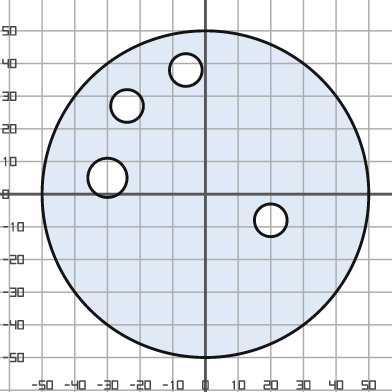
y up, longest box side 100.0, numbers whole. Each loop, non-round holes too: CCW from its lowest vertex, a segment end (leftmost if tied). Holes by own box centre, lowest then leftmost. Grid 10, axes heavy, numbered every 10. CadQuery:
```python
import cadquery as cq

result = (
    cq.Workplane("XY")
    .moveTo(0.0, 0.0)
    .circle(50.0)
    .moveTo(20.0, -8.0)
    .circle(5.0)
    .moveTo(-30.0, 5.0)
    .circle(6.0)
    .moveTo(-24.0, 27.0)
    .circle(5.0)
    .moveTo(-6.0, 38.0)
    .circle(5.0)
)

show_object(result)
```